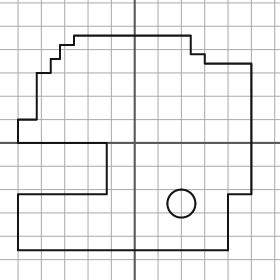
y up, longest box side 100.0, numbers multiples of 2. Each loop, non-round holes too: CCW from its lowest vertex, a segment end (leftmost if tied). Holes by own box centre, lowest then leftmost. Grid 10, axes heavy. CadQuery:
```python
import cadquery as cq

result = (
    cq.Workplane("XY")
    .moveTo(-50.0, -46.0)
    .lineTo(40.0, -46.0)
    .lineTo(40.0, -22.0)
    .lineTo(50.0, -22.0)
    .lineTo(50.0, 34.0)
    .lineTo(30.0, 34.0)
    .lineTo(30.0, 38.0)
    .lineTo(24.0, 38.0)
    .lineTo(24.0, 46.0)
    .lineTo(-26.0, 46.0)
    .lineTo(-26.0, 42.0)
    .lineTo(-32.0, 42.0)
    .lineTo(-32.0, 36.0)
    .lineTo(-36.0, 36.0)
    .lineTo(-36.0, 30.0)
    .lineTo(-42.0, 30.0)
    .lineTo(-42.0, 10.0)
    .lineTo(-50.0, 10.0)
    .lineTo(-50.0, 0.0)
    .lineTo(-12.0, 0.0)
    .lineTo(-12.0, -22.0)
    .lineTo(-50.0, -22.0)
    .close()
    .moveTo(20.0, -26.0)
    .circle(6.0)
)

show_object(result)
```